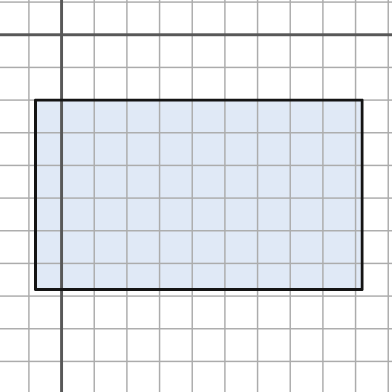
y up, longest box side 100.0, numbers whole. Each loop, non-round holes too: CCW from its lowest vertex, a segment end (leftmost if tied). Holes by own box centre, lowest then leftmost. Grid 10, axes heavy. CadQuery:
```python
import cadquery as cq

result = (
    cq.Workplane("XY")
    .moveTo(-8.0, -78.0)
    .lineTo(92.0, -78.0)
    .lineTo(92.0, -20.0)
    .lineTo(-8.0, -20.0)
    .close()
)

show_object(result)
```